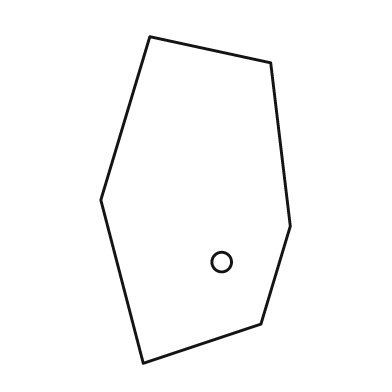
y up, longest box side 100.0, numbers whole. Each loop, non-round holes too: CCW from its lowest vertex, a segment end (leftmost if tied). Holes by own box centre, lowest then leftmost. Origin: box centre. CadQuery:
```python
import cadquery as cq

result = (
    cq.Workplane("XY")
    .moveTo(-16.0, -50.0)
    .lineTo(20.0, -38.0)
    .lineTo(29.0, -8.0)
    .lineTo(23.0, 42.0)
    .lineTo(-14.0, 50.0)
    .lineTo(-29.0, 0.0)
    .close()
    .moveTo(8.0, -19.0)
    .circle(3.0)
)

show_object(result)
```